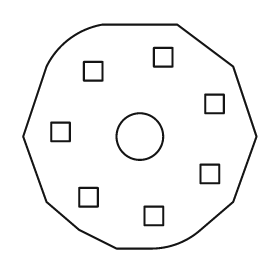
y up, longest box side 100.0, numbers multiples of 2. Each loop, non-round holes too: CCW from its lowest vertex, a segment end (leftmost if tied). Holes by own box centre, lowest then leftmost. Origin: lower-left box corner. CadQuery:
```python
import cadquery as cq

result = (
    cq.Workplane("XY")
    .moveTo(40.0, 0.0)
    .lineTo(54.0, 0.0)
    .threePointArc((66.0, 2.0), (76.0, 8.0))
    .lineTo(90.0, 20.0)
    .lineTo(100.0, 48.0)
    .lineTo(90.0, 78.0)
    .lineTo(66.0, 96.0)
    .lineTo(34.0, 96.0)
    .threePointArc((20.0, 90.0), (10.0, 78.0))
    .lineTo(0.0, 48.0)
    .lineTo(10.0, 20.0)
    .lineTo(24.0, 8.0)
    .close()
    .moveTo(52.0, 10.0)
    .lineTo(60.0, 10.0)
    .lineTo(60.0, 18.0)
    .lineTo(52.0, 18.0)
    .close()
    .moveTo(24.0, 18.0)
    .lineTo(32.0, 18.0)
    .lineTo(32.0, 26.0)
    .lineTo(24.0, 26.0)
    .close()
    .moveTo(76.0, 28.0)
    .lineTo(84.0, 28.0)
    .lineTo(84.0, 36.0)
    .lineTo(76.0, 36.0)
    .close()
    .moveTo(50.0, 48.0)
    .circle(10.0)
    .moveTo(12.0, 46.0)
    .lineTo(20.0, 46.0)
    .lineTo(20.0, 54.0)
    .lineTo(12.0, 54.0)
    .close()
    .moveTo(78.0, 58.0)
    .lineTo(86.0, 58.0)
    .lineTo(86.0, 66.0)
    .lineTo(78.0, 66.0)
    .close()
    .moveTo(26.0, 72.0)
    .lineTo(34.0, 72.0)
    .lineTo(34.0, 80.0)
    .lineTo(26.0, 80.0)
    .close()
    .moveTo(56.0, 78.0)
    .lineTo(64.0, 78.0)
    .lineTo(64.0, 86.0)
    .lineTo(56.0, 86.0)
    .close()
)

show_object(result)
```